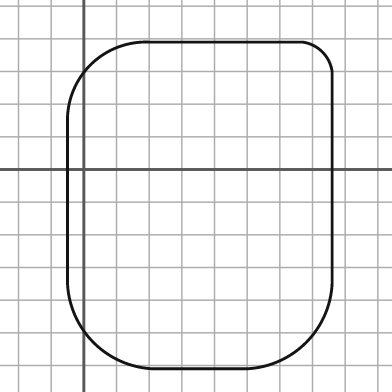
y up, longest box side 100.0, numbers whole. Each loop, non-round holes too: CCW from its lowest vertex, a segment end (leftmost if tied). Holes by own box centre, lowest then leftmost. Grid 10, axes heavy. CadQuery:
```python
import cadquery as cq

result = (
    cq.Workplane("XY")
    .moveTo(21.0, -61.0)
    .lineTo(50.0, -61.0)
    .threePointArc((68.0, -53.0), (76.0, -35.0))
    .lineTo(76.0, 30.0)
    .threePointArc((73.0, 36.0), (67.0, 39.0))
    .lineTo(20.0, 39.0)
    .threePointArc((2.0, 32.0), (-5.0, 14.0))
    .lineTo(-5.0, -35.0)
    .threePointArc((3.0, -53.0), (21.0, -61.0))
    .close()
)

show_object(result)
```